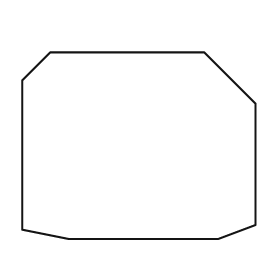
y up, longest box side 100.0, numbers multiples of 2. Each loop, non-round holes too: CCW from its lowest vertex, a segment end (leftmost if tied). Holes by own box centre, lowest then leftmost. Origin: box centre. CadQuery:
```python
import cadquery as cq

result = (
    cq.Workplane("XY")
    .moveTo(-30.0, -40.0)
    .lineTo(34.0, -40.0)
    .lineTo(50.0, -34.0)
    .lineTo(50.0, 18.0)
    .lineTo(28.0, 40.0)
    .lineTo(-38.0, 40.0)
    .lineTo(-50.0, 28.0)
    .lineTo(-50.0, -36.0)
    .close()
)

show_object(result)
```